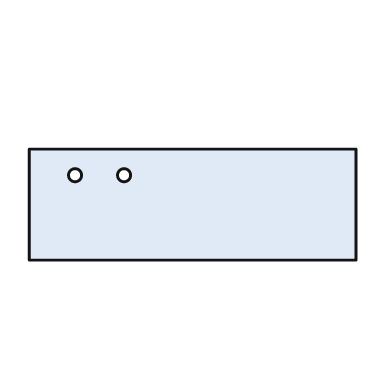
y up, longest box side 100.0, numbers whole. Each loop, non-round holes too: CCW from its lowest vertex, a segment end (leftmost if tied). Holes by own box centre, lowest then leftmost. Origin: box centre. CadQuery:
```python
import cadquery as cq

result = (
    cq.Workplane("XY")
    .moveTo(-50.0, -17.0)
    .lineTo(50.0, -17.0)
    .lineTo(50.0, 17.0)
    .lineTo(-50.0, 17.0)
    .close()
    .moveTo(-36.0, 9.0)
    .circle(2.0)
    .moveTo(-21.0, 9.0)
    .circle(2.0)
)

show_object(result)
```